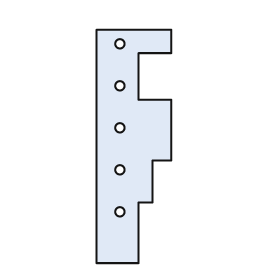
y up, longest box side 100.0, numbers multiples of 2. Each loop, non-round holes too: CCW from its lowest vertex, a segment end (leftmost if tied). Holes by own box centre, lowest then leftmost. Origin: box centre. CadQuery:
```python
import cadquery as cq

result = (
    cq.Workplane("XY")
    .moveTo(-16.0, -50.0)
    .lineTo(2.0, -50.0)
    .lineTo(2.0, -24.0)
    .lineTo(8.0, -24.0)
    .lineTo(8.0, -6.0)
    .lineTo(16.0, -6.0)
    .lineTo(16.0, 20.0)
    .lineTo(2.0, 20.0)
    .lineTo(2.0, 40.0)
    .lineTo(16.0, 40.0)
    .lineTo(16.0, 50.0)
    .lineTo(-16.0, 50.0)
    .close()
    .moveTo(-6.0, -28.0)
    .circle(2.0)
    .moveTo(-6.0, -10.0)
    .circle(2.0)
    .moveTo(-6.0, 8.0)
    .circle(2.0)
    .moveTo(-6.0, 26.0)
    .circle(2.0)
    .moveTo(-6.0, 44.0)
    .circle(2.0)
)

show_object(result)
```